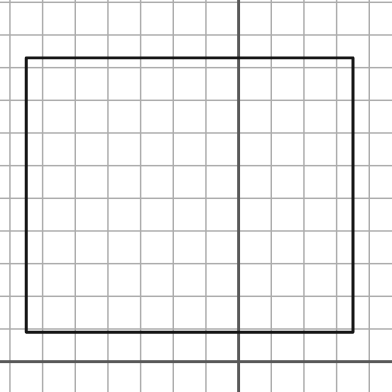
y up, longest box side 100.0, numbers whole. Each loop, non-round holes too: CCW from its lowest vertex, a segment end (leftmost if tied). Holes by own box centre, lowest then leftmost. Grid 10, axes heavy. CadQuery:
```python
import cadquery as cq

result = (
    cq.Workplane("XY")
    .moveTo(-65.0, 9.0)
    .lineTo(35.0, 9.0)
    .lineTo(35.0, 93.0)
    .lineTo(-65.0, 93.0)
    .close()
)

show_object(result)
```